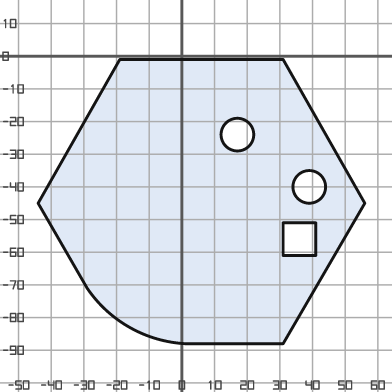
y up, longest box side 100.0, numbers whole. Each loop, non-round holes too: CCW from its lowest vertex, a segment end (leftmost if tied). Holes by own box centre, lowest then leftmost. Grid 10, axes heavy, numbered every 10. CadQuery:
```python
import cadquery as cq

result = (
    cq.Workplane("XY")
    .moveTo(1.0, -88.0)
    .lineTo(31.0, -88.0)
    .lineTo(56.0, -45.0)
    .lineTo(31.0, -1.0)
    .lineTo(-19.0, -1.0)
    .lineTo(-44.0, -45.0)
    .lineTo(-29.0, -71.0)
    .threePointArc((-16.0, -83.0), (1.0, -88.0))
    .close()
    .moveTo(31.0, -61.0)
    .lineTo(41.0, -61.0)
    .lineTo(41.0, -51.0)
    .lineTo(31.0, -51.0)
    .close()
    .moveTo(39.0, -40.0)
    .circle(5.0)
    .moveTo(17.0, -24.0)
    .circle(5.0)
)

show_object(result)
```